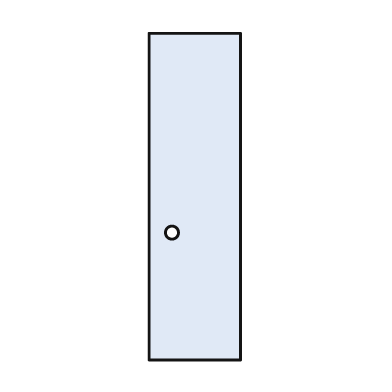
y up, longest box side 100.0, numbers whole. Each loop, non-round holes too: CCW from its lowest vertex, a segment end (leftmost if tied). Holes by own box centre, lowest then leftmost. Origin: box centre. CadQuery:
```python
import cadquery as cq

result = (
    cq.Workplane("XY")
    .moveTo(-14.0, -50.0)
    .lineTo(14.0, -50.0)
    .lineTo(14.0, 50.0)
    .lineTo(-14.0, 50.0)
    .close()
    .moveTo(-7.0, -11.0)
    .circle(2.0)
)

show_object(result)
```